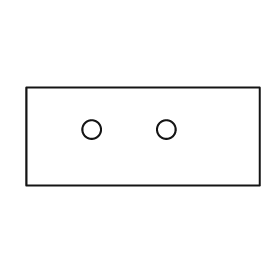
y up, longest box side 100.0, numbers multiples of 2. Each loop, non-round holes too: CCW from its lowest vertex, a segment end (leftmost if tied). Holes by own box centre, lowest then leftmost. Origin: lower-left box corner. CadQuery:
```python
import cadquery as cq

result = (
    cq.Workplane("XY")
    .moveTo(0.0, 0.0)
    .lineTo(100.0, 0.0)
    .lineTo(100.0, 42.0)
    .lineTo(0.0, 42.0)
    .close()
    .moveTo(28.0, 24.0)
    .circle(4.0)
    .moveTo(60.0, 24.0)
    .circle(4.0)
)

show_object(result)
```